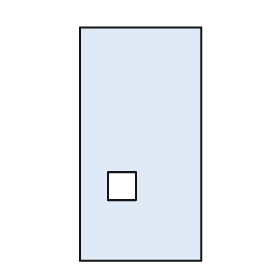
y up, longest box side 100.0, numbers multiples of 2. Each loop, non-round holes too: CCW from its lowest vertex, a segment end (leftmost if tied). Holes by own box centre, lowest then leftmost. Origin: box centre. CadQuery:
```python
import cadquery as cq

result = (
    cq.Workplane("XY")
    .moveTo(-26.0, -50.0)
    .lineTo(26.0, -50.0)
    .lineTo(26.0, 50.0)
    .lineTo(-26.0, 50.0)
    .close()
    .moveTo(-14.0, -24.0)
    .lineTo(-2.0, -24.0)
    .lineTo(-2.0, -12.0)
    .lineTo(-14.0, -12.0)
    .close()
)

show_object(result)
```